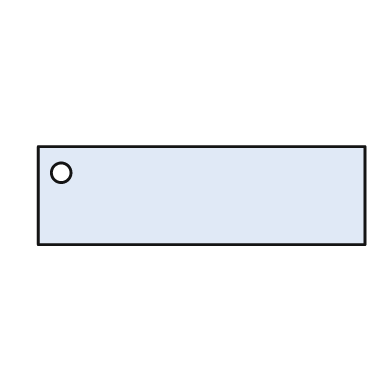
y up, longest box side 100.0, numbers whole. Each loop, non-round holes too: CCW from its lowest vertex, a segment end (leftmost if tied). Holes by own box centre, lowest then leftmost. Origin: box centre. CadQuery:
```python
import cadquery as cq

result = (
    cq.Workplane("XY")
    .moveTo(-50.0, -15.0)
    .lineTo(50.0, -15.0)
    .lineTo(50.0, 15.0)
    .lineTo(-50.0, 15.0)
    .close()
    .moveTo(-43.0, 7.0)
    .circle(3.0)
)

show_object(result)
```